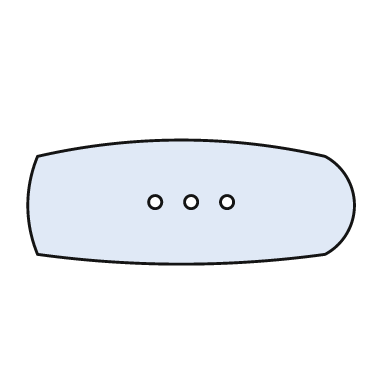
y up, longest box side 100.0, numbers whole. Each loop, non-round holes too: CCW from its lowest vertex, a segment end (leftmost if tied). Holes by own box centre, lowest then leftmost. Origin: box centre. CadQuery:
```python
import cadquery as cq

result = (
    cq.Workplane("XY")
    .moveTo(-47.0, -16.0)
    .threePointArc((-3.0, -19.0), (41.0, -16.0))
    .threePointArc((50.0, -1.0), (41.0, 14.0))
    .threePointArc((-3.0, 19.0), (-47.0, 14.0))
    .threePointArc((-50.0, -1.0), (-47.0, -16.0))
    .close()
    .moveTo(-11.0, 0.0)
    .circle(2.0)
    .moveTo(0.0, 0.0)
    .circle(2.0)
    .moveTo(11.0, 0.0)
    .circle(2.0)
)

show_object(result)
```